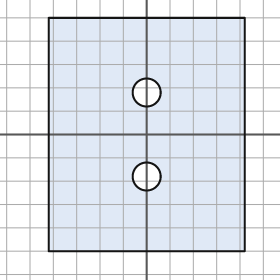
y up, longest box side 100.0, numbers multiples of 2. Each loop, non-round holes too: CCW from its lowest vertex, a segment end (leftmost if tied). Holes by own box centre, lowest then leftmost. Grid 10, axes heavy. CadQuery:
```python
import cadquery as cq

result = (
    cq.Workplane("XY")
    .moveTo(-42.0, -50.0)
    .lineTo(42.0, -50.0)
    .lineTo(42.0, 50.0)
    .lineTo(-42.0, 50.0)
    .close()
    .moveTo(0.0, -18.0)
    .circle(6.0)
    .moveTo(0.0, 18.0)
    .circle(6.0)
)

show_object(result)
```